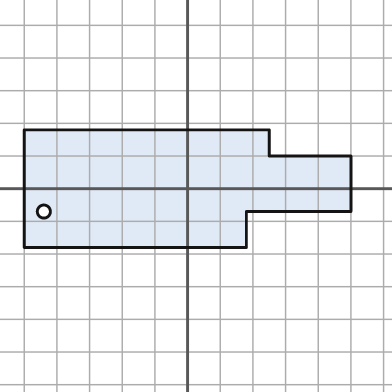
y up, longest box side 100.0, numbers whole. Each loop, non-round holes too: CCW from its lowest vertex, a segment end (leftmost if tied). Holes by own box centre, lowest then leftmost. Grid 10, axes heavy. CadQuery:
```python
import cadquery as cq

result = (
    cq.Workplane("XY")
    .moveTo(-50.0, -18.0)
    .lineTo(18.0, -18.0)
    .lineTo(18.0, -7.0)
    .lineTo(50.0, -7.0)
    .lineTo(50.0, 10.0)
    .lineTo(25.0, 10.0)
    .lineTo(25.0, 18.0)
    .lineTo(-50.0, 18.0)
    .close()
    .moveTo(-44.0, -7.0)
    .circle(2.0)
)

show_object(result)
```